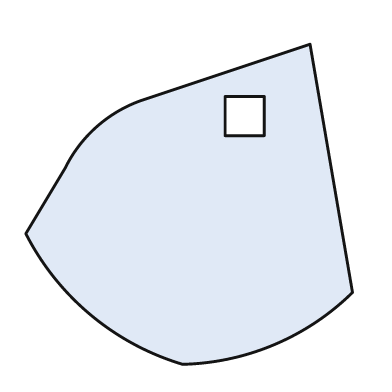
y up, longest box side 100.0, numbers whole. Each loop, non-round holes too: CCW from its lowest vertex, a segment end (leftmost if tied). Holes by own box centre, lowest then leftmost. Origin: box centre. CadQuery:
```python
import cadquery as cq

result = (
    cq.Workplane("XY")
    .moveTo(-2.0, -49.0)
    .threePointArc((26.0, -43.0), (50.0, -27.0))
    .lineTo(37.0, 49.0)
    .lineTo(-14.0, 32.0)
    .threePointArc((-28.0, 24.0), (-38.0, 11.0))
    .lineTo(-50.0, -9.0)
    .threePointArc((-30.0, -34.0), (-2.0, -49.0))
    .close()
    .moveTo(11.0, 21.0)
    .lineTo(23.0, 21.0)
    .lineTo(23.0, 33.0)
    .lineTo(11.0, 33.0)
    .close()
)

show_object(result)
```